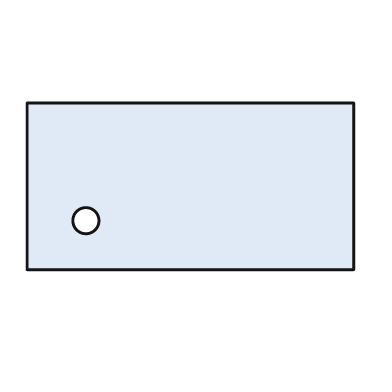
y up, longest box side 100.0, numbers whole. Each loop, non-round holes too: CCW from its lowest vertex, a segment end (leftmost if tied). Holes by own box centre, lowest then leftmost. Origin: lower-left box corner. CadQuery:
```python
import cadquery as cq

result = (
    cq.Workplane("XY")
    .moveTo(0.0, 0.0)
    .lineTo(100.0, 0.0)
    .lineTo(100.0, 51.0)
    .lineTo(0.0, 51.0)
    .close()
    .moveTo(18.0, 15.0)
    .circle(4.0)
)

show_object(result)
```